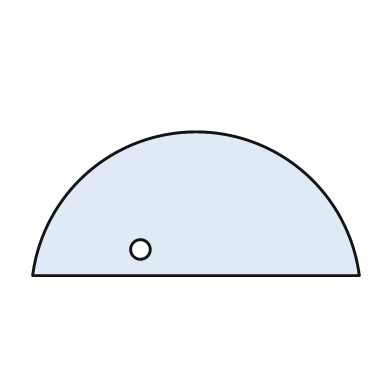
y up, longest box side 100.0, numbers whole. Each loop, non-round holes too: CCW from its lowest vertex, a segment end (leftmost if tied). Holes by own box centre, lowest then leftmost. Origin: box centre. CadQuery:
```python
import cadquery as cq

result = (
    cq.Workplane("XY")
    .moveTo(-50.0, -22.0)
    .lineTo(50.0, -22.0)
    .threePointArc((0.0, 22.0), (-50.0, -22.0))
    .close()
    .moveTo(-17.0, -14.0)
    .circle(3.0)
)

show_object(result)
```